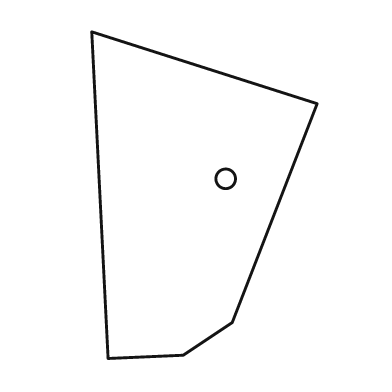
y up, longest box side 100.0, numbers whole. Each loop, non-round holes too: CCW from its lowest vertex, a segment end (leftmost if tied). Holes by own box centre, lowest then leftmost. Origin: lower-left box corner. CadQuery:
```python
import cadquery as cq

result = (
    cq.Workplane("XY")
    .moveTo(5.0, 0.0)
    .lineTo(28.0, 1.0)
    .lineTo(43.0, 11.0)
    .lineTo(69.0, 78.0)
    .lineTo(0.0, 100.0)
    .close()
    .moveTo(41.0, 55.0)
    .circle(3.0)
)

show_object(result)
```